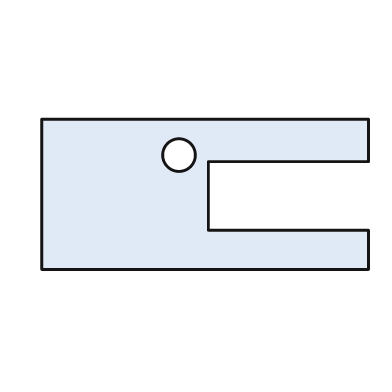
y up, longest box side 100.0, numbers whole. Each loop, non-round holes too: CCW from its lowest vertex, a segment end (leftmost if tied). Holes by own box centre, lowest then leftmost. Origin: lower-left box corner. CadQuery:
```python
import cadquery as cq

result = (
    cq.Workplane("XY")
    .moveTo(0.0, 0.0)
    .lineTo(100.0, 0.0)
    .lineTo(100.0, 12.0)
    .lineTo(51.0, 12.0)
    .lineTo(51.0, 33.0)
    .lineTo(100.0, 33.0)
    .lineTo(100.0, 46.0)
    .lineTo(0.0, 46.0)
    .close()
    .moveTo(42.0, 35.0)
    .circle(5.0)
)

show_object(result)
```